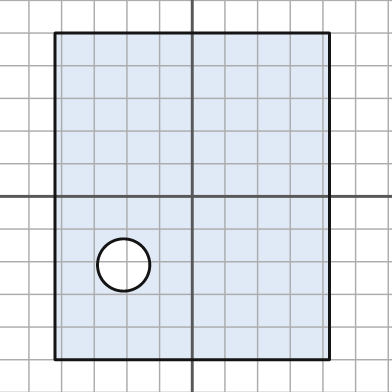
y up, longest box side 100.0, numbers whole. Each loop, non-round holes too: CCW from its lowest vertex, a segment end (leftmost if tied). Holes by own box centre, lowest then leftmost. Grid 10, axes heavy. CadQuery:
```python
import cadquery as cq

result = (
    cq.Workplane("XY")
    .moveTo(-42.0, -50.0)
    .lineTo(42.0, -50.0)
    .lineTo(42.0, 50.0)
    .lineTo(-42.0, 50.0)
    .close()
    .moveTo(-21.0, -21.0)
    .circle(8.0)
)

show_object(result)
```